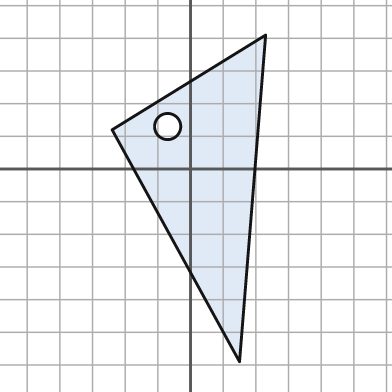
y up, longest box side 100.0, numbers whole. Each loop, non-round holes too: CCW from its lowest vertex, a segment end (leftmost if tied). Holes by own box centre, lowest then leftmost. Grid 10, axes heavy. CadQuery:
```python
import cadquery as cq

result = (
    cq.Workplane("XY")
    .moveTo(15.0, -59.0)
    .lineTo(23.0, 41.0)
    .lineTo(-24.0, 12.0)
    .close()
    .moveTo(-7.0, 13.0)
    .circle(4.0)
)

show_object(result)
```